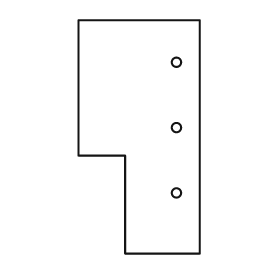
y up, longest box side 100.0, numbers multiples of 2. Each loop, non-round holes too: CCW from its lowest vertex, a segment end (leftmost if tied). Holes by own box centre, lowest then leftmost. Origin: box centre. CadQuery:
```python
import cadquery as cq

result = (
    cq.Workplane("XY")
    .moveTo(-6.0, -50.0)
    .lineTo(26.0, -50.0)
    .lineTo(26.0, 50.0)
    .lineTo(-26.0, 50.0)
    .lineTo(-26.0, -8.0)
    .lineTo(-6.0, -8.0)
    .close()
    .moveTo(16.0, -24.0)
    .circle(2.0)
    .moveTo(16.0, 4.0)
    .circle(2.0)
    .moveTo(16.0, 32.0)
    .circle(2.0)
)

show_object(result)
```